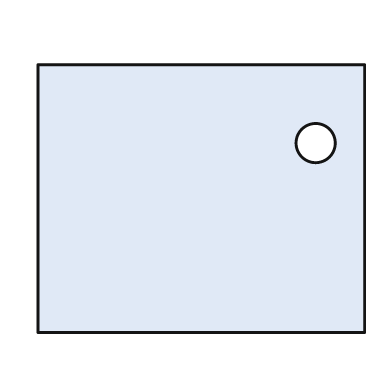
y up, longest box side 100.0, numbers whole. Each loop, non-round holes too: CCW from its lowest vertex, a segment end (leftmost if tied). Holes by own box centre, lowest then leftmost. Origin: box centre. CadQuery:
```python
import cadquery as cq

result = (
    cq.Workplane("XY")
    .moveTo(-50.0, -41.0)
    .lineTo(50.0, -41.0)
    .lineTo(50.0, 41.0)
    .lineTo(-50.0, 41.0)
    .close()
    .moveTo(35.0, 17.0)
    .circle(6.0)
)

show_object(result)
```